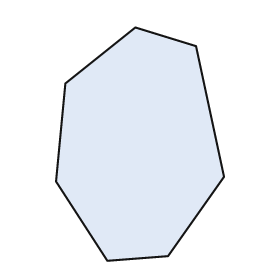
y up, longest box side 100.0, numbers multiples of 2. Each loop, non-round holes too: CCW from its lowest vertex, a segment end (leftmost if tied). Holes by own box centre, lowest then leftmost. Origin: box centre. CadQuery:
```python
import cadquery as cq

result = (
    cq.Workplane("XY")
    .moveTo(-14.0, -50.0)
    .lineTo(12.0, -48.0)
    .lineTo(36.0, -14.0)
    .lineTo(24.0, 42.0)
    .lineTo(-2.0, 50.0)
    .lineTo(-32.0, 26.0)
    .lineTo(-36.0, -16.0)
    .close()
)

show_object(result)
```